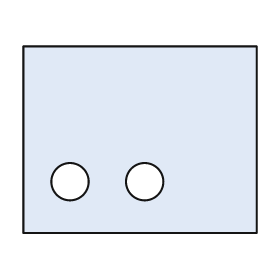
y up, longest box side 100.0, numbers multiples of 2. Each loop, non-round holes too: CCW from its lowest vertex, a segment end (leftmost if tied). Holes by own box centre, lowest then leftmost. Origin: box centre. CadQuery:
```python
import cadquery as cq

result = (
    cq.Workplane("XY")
    .moveTo(-50.0, -40.0)
    .lineTo(50.0, -40.0)
    .lineTo(50.0, 40.0)
    .lineTo(-50.0, 40.0)
    .close()
    .moveTo(-30.0, -18.0)
    .circle(8.0)
    .moveTo(2.0, -18.0)
    .circle(8.0)
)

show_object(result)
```